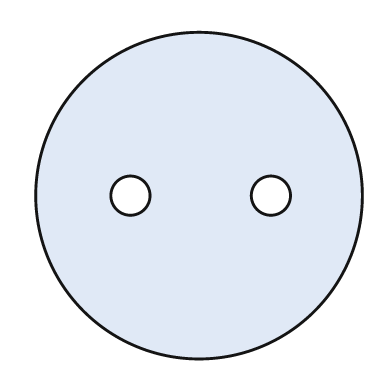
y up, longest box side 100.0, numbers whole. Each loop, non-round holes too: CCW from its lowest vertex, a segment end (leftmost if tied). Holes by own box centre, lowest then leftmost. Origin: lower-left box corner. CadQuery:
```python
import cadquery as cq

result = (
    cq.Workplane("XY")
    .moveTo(50.0, 50.0)
    .circle(50.0)
    .moveTo(29.0, 50.0)
    .circle(6.0)
    .moveTo(72.0, 50.0)
    .circle(6.0)
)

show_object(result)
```